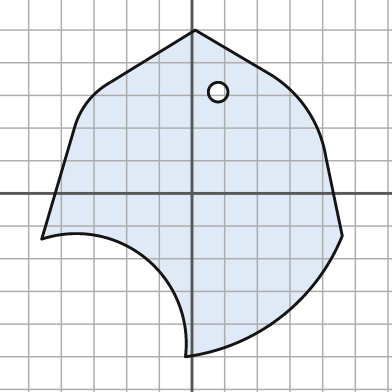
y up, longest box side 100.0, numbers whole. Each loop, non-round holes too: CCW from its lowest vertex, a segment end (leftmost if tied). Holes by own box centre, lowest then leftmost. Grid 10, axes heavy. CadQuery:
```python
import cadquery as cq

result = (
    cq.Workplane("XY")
    .moveTo(-2.0, -50.0)
    .threePointArc((27.0, -38.0), (46.0, -13.0))
    .lineTo(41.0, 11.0)
    .threePointArc((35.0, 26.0), (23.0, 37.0))
    .lineTo(1.0, 50.0)
    .lineTo(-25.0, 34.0)
    .threePointArc((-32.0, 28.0), (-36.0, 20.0))
    .lineTo(-46.0, -14.0)
    .threePointArc((-14.0, -20.0), (-2.0, -50.0))
    .close()
    .moveTo(8.0, 31.0)
    .circle(3.0)
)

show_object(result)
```